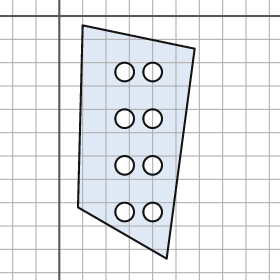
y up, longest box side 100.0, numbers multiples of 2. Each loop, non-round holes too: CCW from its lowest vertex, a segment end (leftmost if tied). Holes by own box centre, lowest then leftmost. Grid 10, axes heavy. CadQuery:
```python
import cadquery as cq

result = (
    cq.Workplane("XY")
    .moveTo(46.0, -104.0)
    .lineTo(58.0, -14.0)
    .lineTo(10.0, -4.0)
    .lineTo(8.0, -82.0)
    .close()
    .moveTo(28.0, -84.0)
    .circle(4.0)
    .moveTo(40.0, -84.0)
    .circle(4.0)
    .moveTo(28.0, -64.0)
    .circle(4.0)
    .moveTo(40.0, -64.0)
    .circle(4.0)
    .moveTo(28.0, -44.0)
    .circle(4.0)
    .moveTo(40.0, -44.0)
    .circle(4.0)
    .moveTo(28.0, -24.0)
    .circle(4.0)
    .moveTo(40.0, -24.0)
    .circle(4.0)
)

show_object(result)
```